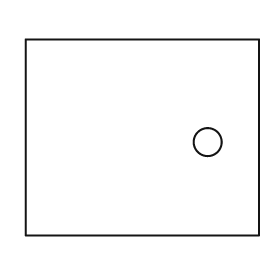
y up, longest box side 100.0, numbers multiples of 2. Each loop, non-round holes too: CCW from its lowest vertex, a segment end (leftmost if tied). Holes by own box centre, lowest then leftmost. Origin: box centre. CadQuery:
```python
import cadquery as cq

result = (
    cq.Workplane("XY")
    .moveTo(-50.0, -42.0)
    .lineTo(50.0, -42.0)
    .lineTo(50.0, 42.0)
    .lineTo(-50.0, 42.0)
    .close()
    .moveTo(28.0, -2.0)
    .circle(6.0)
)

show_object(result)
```